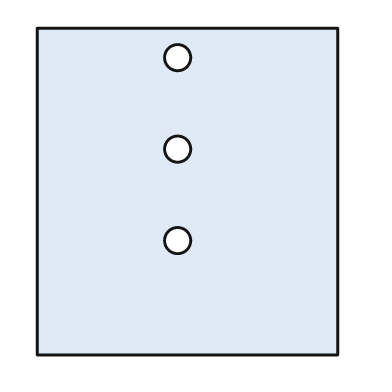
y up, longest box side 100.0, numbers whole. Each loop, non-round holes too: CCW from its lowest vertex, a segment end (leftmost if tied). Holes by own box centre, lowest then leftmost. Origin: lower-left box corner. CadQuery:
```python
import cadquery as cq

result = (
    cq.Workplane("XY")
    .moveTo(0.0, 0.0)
    .lineTo(92.0, 0.0)
    .lineTo(92.0, 100.0)
    .lineTo(0.0, 100.0)
    .close()
    .moveTo(43.0, 35.0)
    .circle(4.0)
    .moveTo(43.0, 63.0)
    .circle(4.0)
    .moveTo(43.0, 91.0)
    .circle(4.0)
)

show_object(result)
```